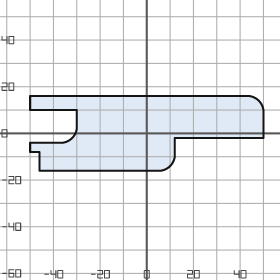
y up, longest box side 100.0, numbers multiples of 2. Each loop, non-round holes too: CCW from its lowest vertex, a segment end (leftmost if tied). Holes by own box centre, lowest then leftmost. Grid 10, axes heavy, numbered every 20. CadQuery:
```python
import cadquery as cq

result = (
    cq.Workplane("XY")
    .moveTo(-46.0, -16.0)
    .lineTo(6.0, -16.0)
    .threePointArc((10.0, -14.0), (12.0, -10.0))
    .lineTo(12.0, -2.0)
    .lineTo(50.0, -2.0)
    .lineTo(50.0, 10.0)
    .threePointArc((48.0, 14.0), (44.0, 16.0))
    .lineTo(-50.0, 16.0)
    .lineTo(-50.0, 10.0)
    .lineTo(-30.0, 10.0)
    .lineTo(-30.0, 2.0)
    .threePointArc((-32.0, -2.0), (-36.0, -4.0))
    .lineTo(-50.0, -4.0)
    .lineTo(-50.0, -8.0)
    .lineTo(-46.0, -8.0)
    .close()
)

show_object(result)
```